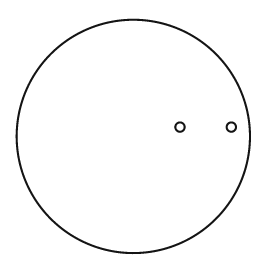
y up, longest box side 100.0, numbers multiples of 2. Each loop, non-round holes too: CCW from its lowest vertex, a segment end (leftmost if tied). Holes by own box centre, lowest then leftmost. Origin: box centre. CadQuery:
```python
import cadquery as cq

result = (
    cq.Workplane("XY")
    .moveTo(0.0, 0.0)
    .circle(50.0)
    .moveTo(20.0, 4.0)
    .circle(2.0)
    .moveTo(42.0, 4.0)
    .circle(2.0)
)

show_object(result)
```